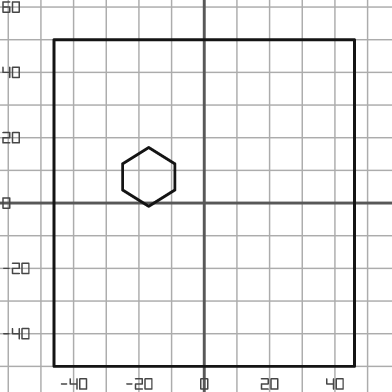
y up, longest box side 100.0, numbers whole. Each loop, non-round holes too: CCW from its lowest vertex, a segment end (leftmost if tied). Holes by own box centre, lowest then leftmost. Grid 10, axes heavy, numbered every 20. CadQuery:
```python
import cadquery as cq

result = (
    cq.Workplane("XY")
    .moveTo(-46.0, -50.0)
    .lineTo(46.0, -50.0)
    .lineTo(46.0, 50.0)
    .lineTo(-46.0, 50.0)
    .close()
    .moveTo(-17.0, -1.0)
    .lineTo(-9.0, 4.0)
    .lineTo(-9.0, 12.0)
    .lineTo(-17.0, 17.0)
    .lineTo(-25.0, 12.0)
    .lineTo(-25.0, 4.0)
    .close()
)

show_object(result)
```